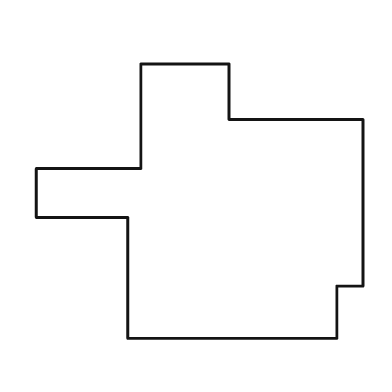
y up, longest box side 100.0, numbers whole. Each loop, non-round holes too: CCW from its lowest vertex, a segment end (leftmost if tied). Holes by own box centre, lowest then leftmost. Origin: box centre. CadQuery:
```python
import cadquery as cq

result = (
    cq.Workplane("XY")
    .moveTo(-22.0, -42.0)
    .lineTo(42.0, -42.0)
    .lineTo(42.0, -26.0)
    .lineTo(50.0, -26.0)
    .lineTo(50.0, 25.0)
    .lineTo(9.0, 25.0)
    .lineTo(9.0, 42.0)
    .lineTo(-18.0, 42.0)
    .lineTo(-18.0, 10.0)
    .lineTo(-50.0, 10.0)
    .lineTo(-50.0, -5.0)
    .lineTo(-22.0, -5.0)
    .close()
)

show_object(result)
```